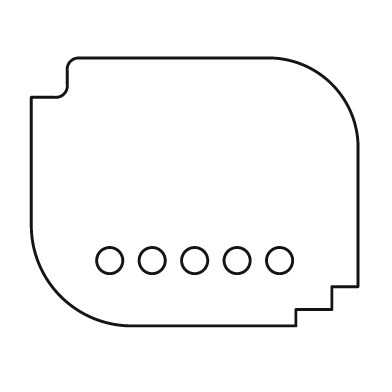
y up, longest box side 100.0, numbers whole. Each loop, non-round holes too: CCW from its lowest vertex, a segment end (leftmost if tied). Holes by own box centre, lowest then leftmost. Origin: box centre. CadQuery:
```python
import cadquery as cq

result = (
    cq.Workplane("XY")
    .moveTo(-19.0, -41.0)
    .lineTo(31.0, -41.0)
    .lineTo(31.0, -36.0)
    .lineTo(42.0, -36.0)
    .lineTo(42.0, -29.0)
    .lineTo(50.0, -29.0)
    .lineTo(50.0, 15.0)
    .threePointArc((42.0, 33.0), (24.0, 41.0))
    .lineTo(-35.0, 41.0)
    .threePointArc((-38.0, 40.0), (-39.0, 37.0))
    .lineTo(-39.0, 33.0)
    .threePointArc((-40.0, 30.0), (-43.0, 29.0))
    .lineTo(-50.0, 29.0)
    .lineTo(-50.0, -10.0)
    .threePointArc((-41.0, -32.0), (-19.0, -41.0))
    .close()
    .moveTo(-26.0, -21.0)
    .circle(4.0)
    .moveTo(-13.0, -21.0)
    .circle(4.0)
    .moveTo(0.0, -21.0)
    .circle(4.0)
    .moveTo(13.0, -21.0)
    .circle(4.0)
    .moveTo(26.0, -21.0)
    .circle(4.0)
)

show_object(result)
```